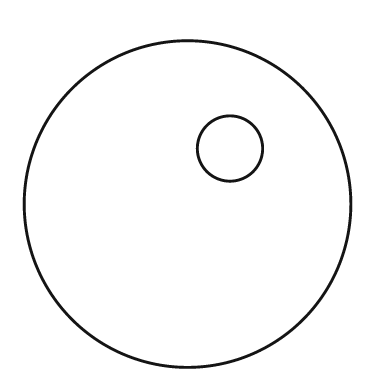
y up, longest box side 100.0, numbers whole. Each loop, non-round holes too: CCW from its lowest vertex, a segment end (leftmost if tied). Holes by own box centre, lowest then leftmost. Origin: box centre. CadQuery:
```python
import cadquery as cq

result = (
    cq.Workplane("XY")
    .moveTo(0.0, 0.0)
    .circle(50.0)
    .moveTo(13.0, 17.0)
    .circle(10.0)
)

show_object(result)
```